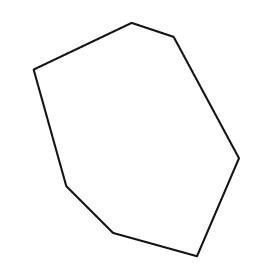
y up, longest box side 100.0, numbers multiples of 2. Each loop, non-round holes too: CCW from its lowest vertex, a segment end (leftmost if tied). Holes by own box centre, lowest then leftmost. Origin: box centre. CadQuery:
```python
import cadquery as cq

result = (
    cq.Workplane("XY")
    .moveTo(26.0, -50.0)
    .lineTo(44.0, -8.0)
    .lineTo(16.0, 44.0)
    .lineTo(-2.0, 50.0)
    .lineTo(-44.0, 30.0)
    .lineTo(-30.0, -20.0)
    .lineTo(-10.0, -40.0)
    .close()
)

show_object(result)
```